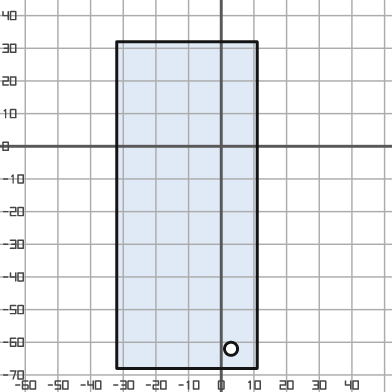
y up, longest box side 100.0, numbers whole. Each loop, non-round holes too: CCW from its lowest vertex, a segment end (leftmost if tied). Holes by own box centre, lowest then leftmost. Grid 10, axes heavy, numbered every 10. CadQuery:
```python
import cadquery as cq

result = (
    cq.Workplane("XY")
    .moveTo(-32.0, -68.0)
    .lineTo(11.0, -68.0)
    .lineTo(11.0, 32.0)
    .lineTo(-32.0, 32.0)
    .close()
    .moveTo(3.0, -62.0)
    .circle(2.0)
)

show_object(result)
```